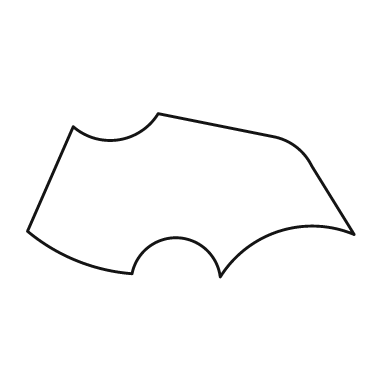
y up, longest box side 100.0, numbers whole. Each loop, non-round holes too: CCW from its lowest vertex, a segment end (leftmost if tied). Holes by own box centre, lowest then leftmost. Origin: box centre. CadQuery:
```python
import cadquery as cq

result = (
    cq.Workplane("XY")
    .moveTo(9.0, -25.0)
    .threePointArc((27.0, -11.0), (50.0, -12.0))
    .lineTo(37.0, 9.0)
    .threePointArc((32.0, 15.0), (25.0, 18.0))
    .lineTo(-10.0, 25.0)
    .threePointArc((-22.0, 17.0), (-36.0, 21.0))
    .lineTo(-50.0, -11.0)
    .threePointArc((-35.0, -20.0), (-18.0, -24.0))
    .threePointArc((-4.0, -13.0), (9.0, -25.0))
    .close()
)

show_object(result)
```